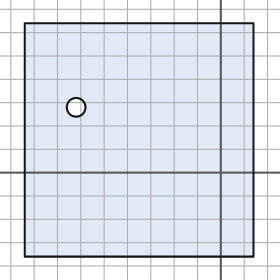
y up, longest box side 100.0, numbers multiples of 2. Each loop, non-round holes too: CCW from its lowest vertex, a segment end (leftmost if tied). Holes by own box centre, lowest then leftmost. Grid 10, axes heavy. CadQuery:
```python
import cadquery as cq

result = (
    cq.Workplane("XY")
    .moveTo(-84.0, -36.0)
    .lineTo(14.0, -36.0)
    .lineTo(14.0, 64.0)
    .lineTo(-84.0, 64.0)
    .close()
    .moveTo(-62.0, 28.0)
    .circle(4.0)
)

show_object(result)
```